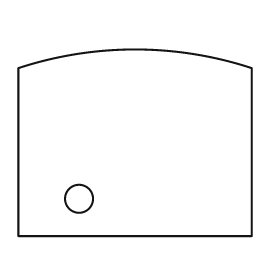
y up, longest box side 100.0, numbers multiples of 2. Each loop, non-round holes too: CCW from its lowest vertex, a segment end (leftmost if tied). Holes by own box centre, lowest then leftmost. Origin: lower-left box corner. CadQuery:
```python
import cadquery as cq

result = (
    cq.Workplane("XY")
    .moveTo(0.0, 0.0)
    .lineTo(100.0, 0.0)
    .lineTo(100.0, 72.0)
    .threePointArc((50.0, 80.0), (0.0, 72.0))
    .close()
    .moveTo(26.0, 16.0)
    .circle(6.0)
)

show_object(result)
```